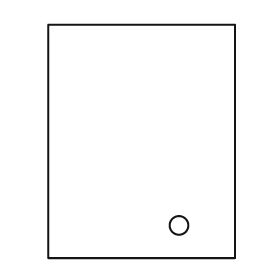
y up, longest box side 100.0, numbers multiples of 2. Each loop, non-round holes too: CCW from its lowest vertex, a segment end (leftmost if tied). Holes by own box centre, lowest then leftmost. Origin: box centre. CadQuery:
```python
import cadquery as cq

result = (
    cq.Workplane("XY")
    .moveTo(-40.0, -50.0)
    .lineTo(40.0, -50.0)
    .lineTo(40.0, 50.0)
    .lineTo(-40.0, 50.0)
    .close()
    .moveTo(16.0, -36.0)
    .circle(4.0)
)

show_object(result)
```